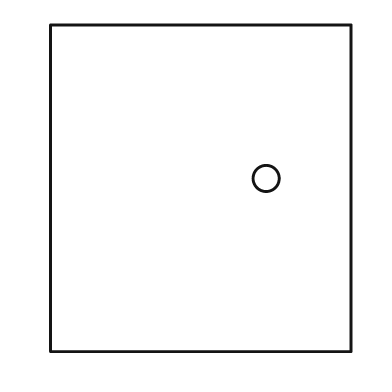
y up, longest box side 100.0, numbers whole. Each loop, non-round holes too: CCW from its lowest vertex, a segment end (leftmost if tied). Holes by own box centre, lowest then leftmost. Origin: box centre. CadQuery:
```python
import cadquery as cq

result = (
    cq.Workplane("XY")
    .moveTo(-46.0, -50.0)
    .lineTo(46.0, -50.0)
    .lineTo(46.0, 50.0)
    .lineTo(-46.0, 50.0)
    .close()
    .moveTo(20.0, 3.0)
    .circle(4.0)
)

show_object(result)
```